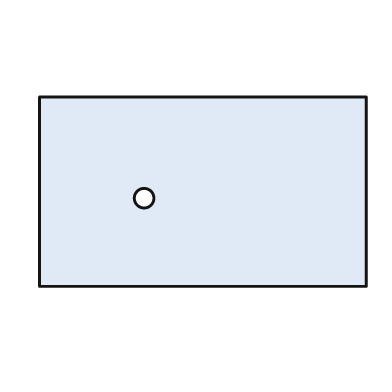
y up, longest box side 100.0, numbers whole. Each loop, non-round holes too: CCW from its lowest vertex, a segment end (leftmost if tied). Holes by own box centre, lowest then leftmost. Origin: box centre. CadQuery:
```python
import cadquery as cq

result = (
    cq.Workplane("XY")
    .moveTo(-50.0, -29.0)
    .lineTo(50.0, -29.0)
    .lineTo(50.0, 29.0)
    .lineTo(-50.0, 29.0)
    .close()
    .moveTo(-18.0, -2.0)
    .circle(3.0)
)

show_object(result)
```